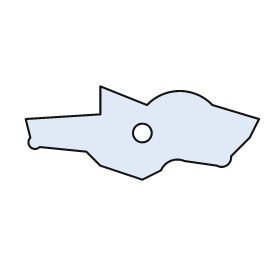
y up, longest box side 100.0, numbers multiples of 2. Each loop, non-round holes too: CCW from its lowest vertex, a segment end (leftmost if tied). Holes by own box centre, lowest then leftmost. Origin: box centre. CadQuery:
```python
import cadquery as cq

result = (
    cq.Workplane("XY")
    .moveTo(0.0, -20.0)
    .lineTo(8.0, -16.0)
    .threePointArc((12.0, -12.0), (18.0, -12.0))
    .lineTo(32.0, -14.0)
    .threePointArc((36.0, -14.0), (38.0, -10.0))
    .lineTo(46.0, -2.0)
    .lineTo(50.0, 6.0)
    .lineTo(30.0, 12.0)
    .threePointArc((16.0, 18.0), (2.0, 12.0))
    .lineTo(-18.0, 20.0)
    .lineTo(-18.0, 8.0)
    .lineTo(-50.0, 6.0)
    .lineTo(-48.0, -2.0)
    .threePointArc((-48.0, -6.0), (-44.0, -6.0))
    .lineTo(-24.0, -8.0)
    .lineTo(-18.0, -14.0)
    .close()
    .moveTo(0.0, 0.0)
    .circle(4.0)
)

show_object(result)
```